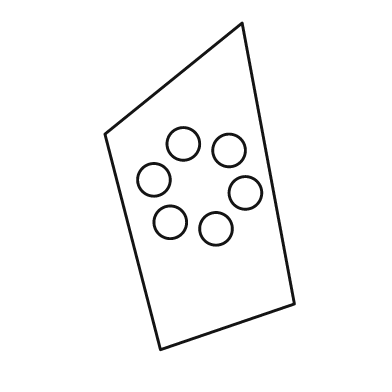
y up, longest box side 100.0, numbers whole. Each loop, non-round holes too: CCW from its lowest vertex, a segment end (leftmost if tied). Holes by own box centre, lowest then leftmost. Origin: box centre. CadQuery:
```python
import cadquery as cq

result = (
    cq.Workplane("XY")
    .moveTo(-12.0, -50.0)
    .lineTo(29.0, -36.0)
    .lineTo(13.0, 50.0)
    .lineTo(-29.0, 16.0)
    .close()
    .moveTo(5.0, -13.0)
    .circle(5.0)
    .moveTo(-9.0, -11.0)
    .circle(5.0)
    .moveTo(14.0, -2.0)
    .circle(5.0)
    .moveTo(-14.0, 2.0)
    .circle(5.0)
    .moveTo(9.0, 11.0)
    .circle(5.0)
    .moveTo(-5.0, 13.0)
    .circle(5.0)
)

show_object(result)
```